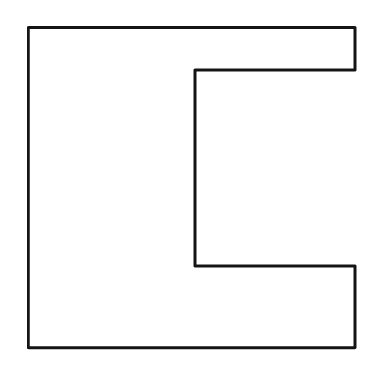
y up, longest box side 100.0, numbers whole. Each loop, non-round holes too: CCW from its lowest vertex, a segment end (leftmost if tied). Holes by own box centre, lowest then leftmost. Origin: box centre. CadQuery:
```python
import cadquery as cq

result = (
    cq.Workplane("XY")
    .moveTo(-50.0, -49.0)
    .lineTo(50.0, -49.0)
    .lineTo(50.0, -24.0)
    .lineTo(1.0, -24.0)
    .lineTo(1.0, 36.0)
    .lineTo(50.0, 36.0)
    .lineTo(50.0, 49.0)
    .lineTo(-50.0, 49.0)
    .close()
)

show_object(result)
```